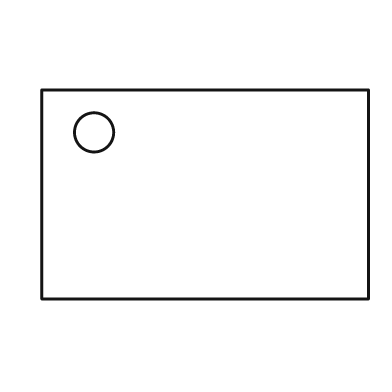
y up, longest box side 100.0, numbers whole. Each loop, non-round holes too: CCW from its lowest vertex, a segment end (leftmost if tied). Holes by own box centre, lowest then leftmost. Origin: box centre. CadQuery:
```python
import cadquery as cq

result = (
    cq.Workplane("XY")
    .moveTo(-50.0, -32.0)
    .lineTo(50.0, -32.0)
    .lineTo(50.0, 32.0)
    .lineTo(-50.0, 32.0)
    .close()
    .moveTo(-34.0, 19.0)
    .circle(6.0)
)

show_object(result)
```